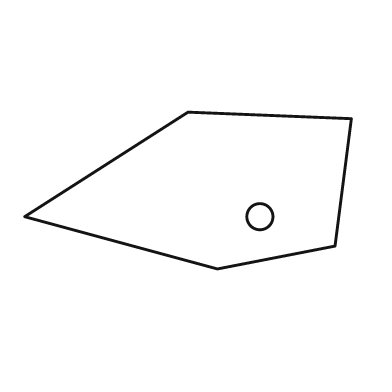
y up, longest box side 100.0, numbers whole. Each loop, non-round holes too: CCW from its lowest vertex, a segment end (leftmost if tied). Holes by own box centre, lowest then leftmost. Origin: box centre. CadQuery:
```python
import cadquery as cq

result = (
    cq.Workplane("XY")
    .moveTo(9.0, -24.0)
    .lineTo(45.0, -17.0)
    .lineTo(50.0, 22.0)
    .lineTo(0.0, 24.0)
    .lineTo(-50.0, -8.0)
    .close()
    .moveTo(22.0, -8.0)
    .circle(4.0)
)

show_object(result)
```